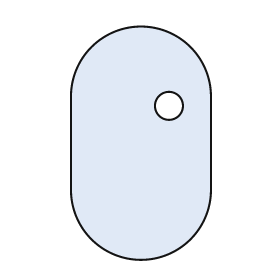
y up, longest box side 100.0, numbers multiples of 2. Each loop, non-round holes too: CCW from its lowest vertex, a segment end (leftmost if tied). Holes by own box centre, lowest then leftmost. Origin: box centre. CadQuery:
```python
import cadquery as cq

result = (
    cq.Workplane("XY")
    .moveTo(-30.0, -20.0)
    .threePointArc((0.0, -50.0), (30.0, -20.0))
    .lineTo(30.0, 20.0)
    .threePointArc((0.0, 50.0), (-30.0, 20.0))
    .close()
    .moveTo(12.0, 16.0)
    .circle(6.0)
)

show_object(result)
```